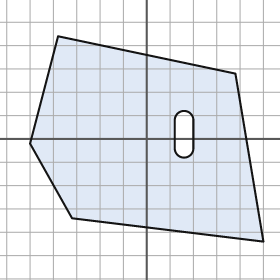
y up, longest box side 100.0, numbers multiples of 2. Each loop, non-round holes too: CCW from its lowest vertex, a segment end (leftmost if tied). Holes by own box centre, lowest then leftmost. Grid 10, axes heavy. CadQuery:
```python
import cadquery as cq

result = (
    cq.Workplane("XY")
    .moveTo(50.0, -44.0)
    .lineTo(38.0, 28.0)
    .lineTo(-38.0, 44.0)
    .lineTo(-50.0, -2.0)
    .lineTo(-32.0, -34.0)
    .close()
    .moveTo(12.0, -4.0)
    .threePointArc((16.0, -8.0), (20.0, -4.0))
    .lineTo(20.0, 8.0)
    .threePointArc((16.0, 12.0), (12.0, 8.0))
    .close()
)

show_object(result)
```